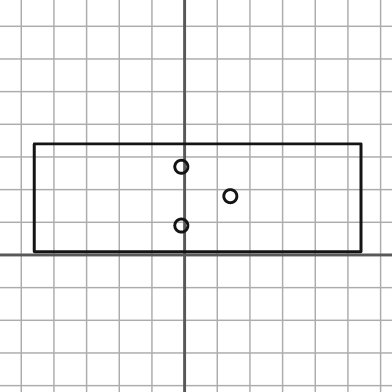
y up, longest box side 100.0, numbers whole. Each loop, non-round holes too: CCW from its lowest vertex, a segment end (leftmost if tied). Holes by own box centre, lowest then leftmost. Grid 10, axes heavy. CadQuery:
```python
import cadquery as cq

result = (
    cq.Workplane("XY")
    .moveTo(-46.0, 1.0)
    .lineTo(54.0, 1.0)
    .lineTo(54.0, 34.0)
    .lineTo(-46.0, 34.0)
    .close()
    .moveTo(-1.0, 9.0)
    .circle(2.0)
    .moveTo(14.0, 18.0)
    .circle(2.0)
    .moveTo(-1.0, 27.0)
    .circle(2.0)
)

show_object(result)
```